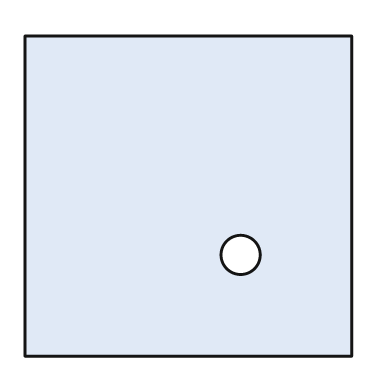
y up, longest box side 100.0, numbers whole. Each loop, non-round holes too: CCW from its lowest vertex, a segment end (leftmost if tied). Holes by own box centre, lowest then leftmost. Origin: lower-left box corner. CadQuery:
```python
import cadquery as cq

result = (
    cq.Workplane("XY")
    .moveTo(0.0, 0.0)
    .lineTo(100.0, 0.0)
    .lineTo(100.0, 98.0)
    .lineTo(0.0, 98.0)
    .close()
    .moveTo(66.0, 31.0)
    .circle(6.0)
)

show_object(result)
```